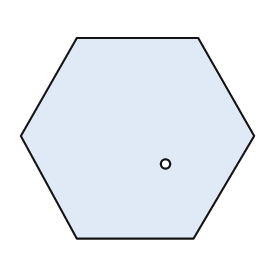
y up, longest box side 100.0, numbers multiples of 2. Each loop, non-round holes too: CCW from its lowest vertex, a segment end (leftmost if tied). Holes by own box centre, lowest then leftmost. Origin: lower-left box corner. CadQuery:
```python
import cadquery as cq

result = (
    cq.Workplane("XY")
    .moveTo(24.0, 0.0)
    .lineTo(74.0, 0.0)
    .lineTo(100.0, 44.0)
    .lineTo(76.0, 86.0)
    .lineTo(24.0, 86.0)
    .lineTo(0.0, 44.0)
    .close()
    .moveTo(62.0, 32.0)
    .circle(2.0)
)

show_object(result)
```